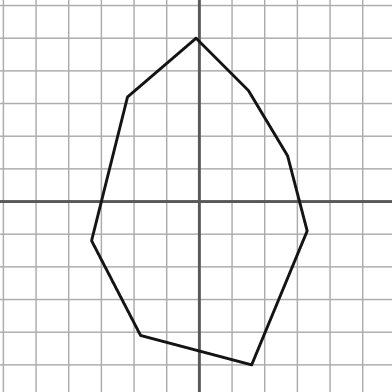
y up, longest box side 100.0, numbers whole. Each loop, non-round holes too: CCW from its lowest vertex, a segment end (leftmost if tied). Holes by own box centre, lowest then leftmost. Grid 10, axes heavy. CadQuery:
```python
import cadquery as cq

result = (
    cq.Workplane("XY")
    .moveTo(16.0, -50.0)
    .lineTo(33.0, -9.0)
    .lineTo(27.0, 14.0)
    .lineTo(15.0, 34.0)
    .lineTo(-1.0, 50.0)
    .lineTo(-22.0, 32.0)
    .lineTo(-33.0, -12.0)
    .lineTo(-18.0, -41.0)
    .close()
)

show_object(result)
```